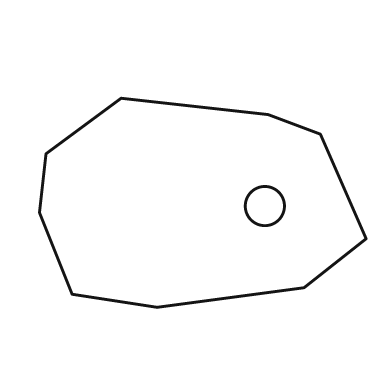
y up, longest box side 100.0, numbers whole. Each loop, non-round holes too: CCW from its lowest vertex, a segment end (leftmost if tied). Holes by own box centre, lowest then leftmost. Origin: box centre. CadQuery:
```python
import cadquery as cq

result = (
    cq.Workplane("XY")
    .moveTo(-14.0, -32.0)
    .lineTo(31.0, -26.0)
    .lineTo(50.0, -11.0)
    .lineTo(36.0, 21.0)
    .lineTo(20.0, 27.0)
    .lineTo(-25.0, 32.0)
    .lineTo(-48.0, 15.0)
    .lineTo(-50.0, -3.0)
    .lineTo(-40.0, -28.0)
    .close()
    .moveTo(19.0, -1.0)
    .circle(6.0)
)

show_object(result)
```